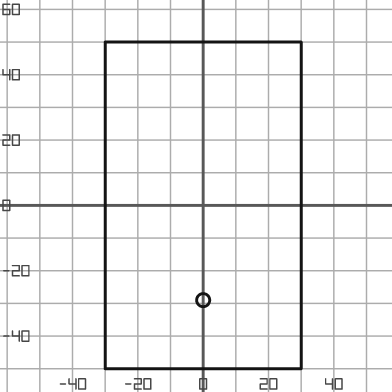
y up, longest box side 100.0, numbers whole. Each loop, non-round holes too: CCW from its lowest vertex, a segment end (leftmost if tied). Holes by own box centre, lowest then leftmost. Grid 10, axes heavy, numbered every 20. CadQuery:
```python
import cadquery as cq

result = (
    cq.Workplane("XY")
    .moveTo(-30.0, -50.0)
    .lineTo(30.0, -50.0)
    .lineTo(30.0, 50.0)
    .lineTo(-30.0, 50.0)
    .close()
    .moveTo(0.0, -29.0)
    .circle(2.0)
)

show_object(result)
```